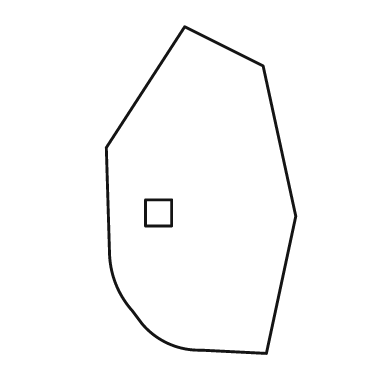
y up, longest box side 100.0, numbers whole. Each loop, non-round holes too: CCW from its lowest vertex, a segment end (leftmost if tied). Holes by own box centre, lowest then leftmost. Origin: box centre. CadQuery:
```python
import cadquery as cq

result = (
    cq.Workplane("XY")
    .moveTo(20.0, -50.0)
    .lineTo(29.0, -8.0)
    .lineTo(19.0, 38.0)
    .lineTo(-5.0, 50.0)
    .lineTo(-29.0, 13.0)
    .lineTo(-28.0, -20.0)
    .threePointArc((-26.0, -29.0), (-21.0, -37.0))
    .lineTo(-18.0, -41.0)
    .threePointArc((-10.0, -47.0), (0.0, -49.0))
    .close()
    .moveTo(-17.0, -11.0)
    .lineTo(-9.0, -11.0)
    .lineTo(-9.0, -3.0)
    .lineTo(-17.0, -3.0)
    .close()
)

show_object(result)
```